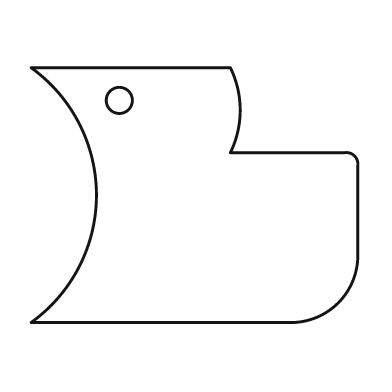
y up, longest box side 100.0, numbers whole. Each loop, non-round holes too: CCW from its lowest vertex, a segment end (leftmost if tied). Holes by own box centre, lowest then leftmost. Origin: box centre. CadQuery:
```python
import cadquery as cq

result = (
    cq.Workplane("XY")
    .moveTo(-50.0, -39.0)
    .lineTo(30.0, -39.0)
    .threePointArc((44.0, -33.0), (50.0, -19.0))
    .lineTo(50.0, 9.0)
    .threePointArc((49.0, 12.0), (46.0, 13.0))
    .lineTo(11.0, 13.0)
    .threePointArc((14.0, 26.0), (11.0, 39.0))
    .lineTo(-50.0, 39.0)
    .threePointArc((-30.0, 0.0), (-50.0, -39.0))
    .close()
    .moveTo(-23.0, 29.0)
    .circle(4.0)
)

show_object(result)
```